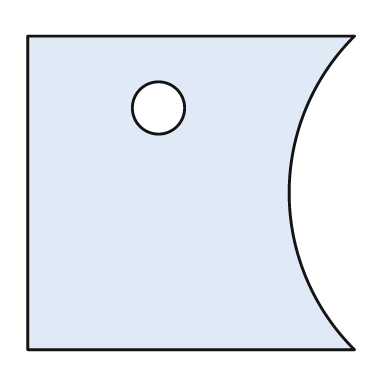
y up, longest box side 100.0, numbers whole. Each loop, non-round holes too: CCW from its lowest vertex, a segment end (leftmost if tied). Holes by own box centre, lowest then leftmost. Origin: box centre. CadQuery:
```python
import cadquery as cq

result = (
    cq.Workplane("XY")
    .moveTo(-50.0, -48.0)
    .lineTo(50.0, -48.0)
    .threePointArc((30.0, 0.0), (50.0, 48.0))
    .lineTo(-50.0, 48.0)
    .close()
    .moveTo(-10.0, 26.0)
    .circle(8.0)
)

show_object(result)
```